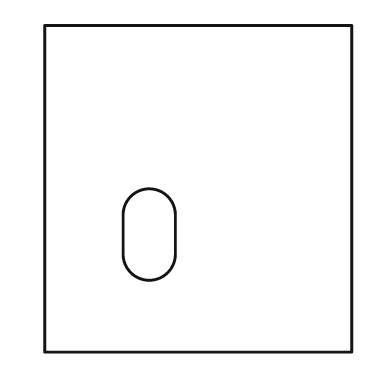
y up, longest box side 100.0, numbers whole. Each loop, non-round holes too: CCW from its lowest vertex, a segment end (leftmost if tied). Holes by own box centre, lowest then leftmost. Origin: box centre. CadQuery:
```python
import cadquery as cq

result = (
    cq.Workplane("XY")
    .moveTo(-47.0, -50.0)
    .lineTo(47.0, -50.0)
    .lineTo(47.0, 50.0)
    .lineTo(-47.0, 50.0)
    .close()
    .moveTo(-23.0, -20.0)
    .threePointArc((-15.0, -28.0), (-7.0, -20.0))
    .lineTo(-7.0, -8.0)
    .threePointArc((-15.0, 0.0), (-23.0, -8.0))
    .close()
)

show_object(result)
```